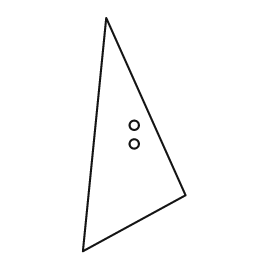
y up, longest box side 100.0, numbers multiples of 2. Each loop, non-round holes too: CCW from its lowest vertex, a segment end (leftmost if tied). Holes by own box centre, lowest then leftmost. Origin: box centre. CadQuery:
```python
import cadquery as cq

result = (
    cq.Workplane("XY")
    .moveTo(-22.0, -50.0)
    .lineTo(22.0, -26.0)
    .lineTo(-12.0, 50.0)
    .close()
    .moveTo(0.0, -4.0)
    .circle(2.0)
    .moveTo(0.0, 4.0)
    .circle(2.0)
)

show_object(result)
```